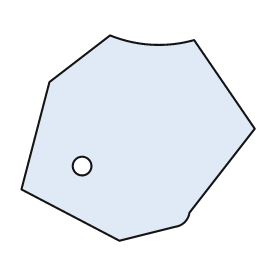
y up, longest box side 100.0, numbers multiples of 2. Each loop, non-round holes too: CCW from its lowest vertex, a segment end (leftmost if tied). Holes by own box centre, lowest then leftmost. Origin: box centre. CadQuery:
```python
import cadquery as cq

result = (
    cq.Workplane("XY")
    .moveTo(-8.0, -44.0)
    .lineTo(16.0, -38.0)
    .threePointArc((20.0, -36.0), (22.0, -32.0))
    .lineTo(50.0, 4.0)
    .lineTo(24.0, 42.0)
    .threePointArc((6.0, 40.0), (-12.0, 44.0))
    .lineTo(-38.0, 24.0)
    .lineTo(-50.0, -22.0)
    .close()
    .moveTo(-24.0, -12.0)
    .circle(4.0)
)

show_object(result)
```